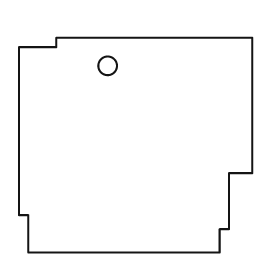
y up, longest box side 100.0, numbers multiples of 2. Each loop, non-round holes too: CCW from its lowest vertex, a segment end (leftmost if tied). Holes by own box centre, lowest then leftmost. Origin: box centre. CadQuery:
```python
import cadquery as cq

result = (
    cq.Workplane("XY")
    .moveTo(-46.0, -46.0)
    .lineTo(36.0, -46.0)
    .lineTo(36.0, -36.0)
    .lineTo(40.0, -36.0)
    .lineTo(40.0, -12.0)
    .lineTo(50.0, -12.0)
    .lineTo(50.0, 46.0)
    .lineTo(-34.0, 46.0)
    .lineTo(-34.0, 42.0)
    .lineTo(-50.0, 42.0)
    .lineTo(-50.0, -30.0)
    .lineTo(-46.0, -30.0)
    .close()
    .moveTo(-12.0, 34.0)
    .circle(4.0)
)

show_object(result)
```